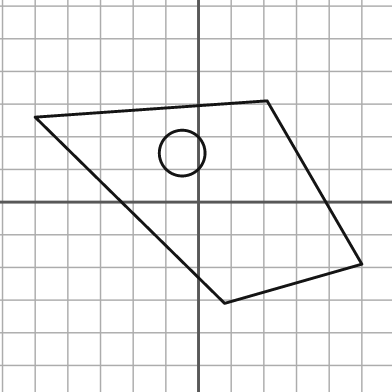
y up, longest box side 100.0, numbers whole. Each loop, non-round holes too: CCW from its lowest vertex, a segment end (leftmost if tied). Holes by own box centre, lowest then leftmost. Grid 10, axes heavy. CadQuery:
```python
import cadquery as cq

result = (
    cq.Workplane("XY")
    .moveTo(8.0, -31.0)
    .lineTo(50.0, -19.0)
    .lineTo(21.0, 31.0)
    .lineTo(-50.0, 26.0)
    .close()
    .moveTo(-5.0, 15.0)
    .circle(7.0)
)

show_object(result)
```